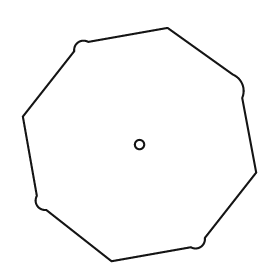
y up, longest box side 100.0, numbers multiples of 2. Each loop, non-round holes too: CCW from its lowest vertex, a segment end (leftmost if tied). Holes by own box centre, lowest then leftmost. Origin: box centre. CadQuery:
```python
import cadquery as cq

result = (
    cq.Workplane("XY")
    .moveTo(-12.0, -50.0)
    .lineTo(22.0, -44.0)
    .threePointArc((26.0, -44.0), (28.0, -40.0))
    .lineTo(50.0, -12.0)
    .lineTo(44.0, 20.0)
    .threePointArc((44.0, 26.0), (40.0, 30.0))
    .lineTo(12.0, 50.0)
    .lineTo(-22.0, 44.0)
    .threePointArc((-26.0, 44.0), (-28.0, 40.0))
    .lineTo(-50.0, 12.0)
    .lineTo(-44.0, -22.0)
    .threePointArc((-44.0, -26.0), (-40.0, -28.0))
    .close()
    .moveTo(0.0, 0.0)
    .circle(2.0)
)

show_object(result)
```